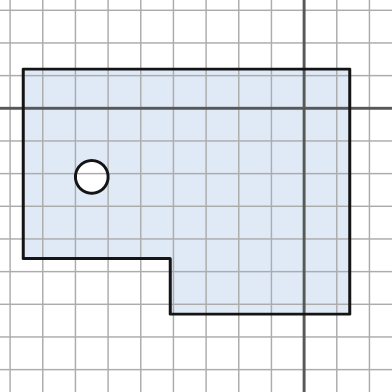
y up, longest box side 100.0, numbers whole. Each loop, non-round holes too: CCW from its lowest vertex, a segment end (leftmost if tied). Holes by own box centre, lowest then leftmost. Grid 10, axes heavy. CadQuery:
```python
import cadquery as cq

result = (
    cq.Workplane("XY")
    .moveTo(-41.0, -63.0)
    .lineTo(14.0, -63.0)
    .lineTo(14.0, 12.0)
    .lineTo(-86.0, 12.0)
    .lineTo(-86.0, -46.0)
    .lineTo(-41.0, -46.0)
    .close()
    .moveTo(-65.0, -21.0)
    .circle(5.0)
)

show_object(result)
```